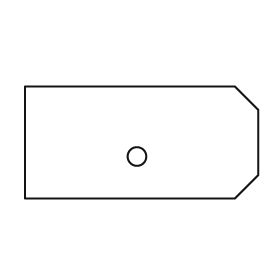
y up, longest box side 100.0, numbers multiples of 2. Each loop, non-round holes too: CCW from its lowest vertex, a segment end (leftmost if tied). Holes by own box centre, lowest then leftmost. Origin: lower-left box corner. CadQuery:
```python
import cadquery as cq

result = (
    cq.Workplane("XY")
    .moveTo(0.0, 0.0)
    .lineTo(90.0, 0.0)
    .lineTo(100.0, 10.0)
    .lineTo(100.0, 38.0)
    .lineTo(90.0, 48.0)
    .lineTo(0.0, 48.0)
    .close()
    .moveTo(48.0, 18.0)
    .circle(4.0)
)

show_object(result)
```